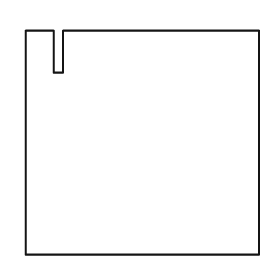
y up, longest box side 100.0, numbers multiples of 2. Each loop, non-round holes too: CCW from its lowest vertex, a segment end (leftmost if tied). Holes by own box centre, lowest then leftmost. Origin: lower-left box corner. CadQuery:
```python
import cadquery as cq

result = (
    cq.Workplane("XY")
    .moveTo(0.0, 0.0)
    .lineTo(100.0, 0.0)
    .lineTo(100.0, 96.0)
    .lineTo(16.0, 96.0)
    .lineTo(16.0, 78.0)
    .lineTo(12.0, 78.0)
    .lineTo(12.0, 96.0)
    .lineTo(0.0, 96.0)
    .close()
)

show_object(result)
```